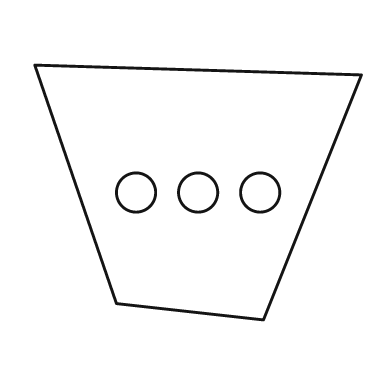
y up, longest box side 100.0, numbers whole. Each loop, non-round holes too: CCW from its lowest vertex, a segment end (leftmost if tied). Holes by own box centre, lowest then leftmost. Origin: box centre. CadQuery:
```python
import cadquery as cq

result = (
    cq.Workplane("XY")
    .moveTo(20.0, -39.0)
    .lineTo(50.0, 36.0)
    .lineTo(-50.0, 39.0)
    .lineTo(-25.0, -34.0)
    .close()
    .moveTo(-19.0, 0.0)
    .circle(6.0)
    .moveTo(0.0, 0.0)
    .circle(6.0)
    .moveTo(19.0, 0.0)
    .circle(6.0)
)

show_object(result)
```